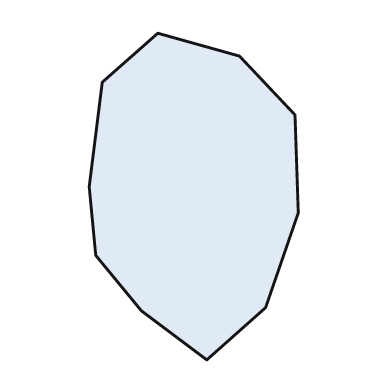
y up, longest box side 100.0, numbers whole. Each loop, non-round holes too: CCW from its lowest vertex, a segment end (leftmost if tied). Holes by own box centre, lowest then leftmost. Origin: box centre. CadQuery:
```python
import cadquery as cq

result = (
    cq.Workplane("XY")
    .moveTo(4.0, -50.0)
    .lineTo(22.0, -34.0)
    .lineTo(32.0, -5.0)
    .lineTo(31.0, 25.0)
    .lineTo(14.0, 43.0)
    .lineTo(-11.0, 50.0)
    .lineTo(-28.0, 35.0)
    .lineTo(-32.0, 3.0)
    .lineTo(-30.0, -18.0)
    .lineTo(-16.0, -35.0)
    .close()
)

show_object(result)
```